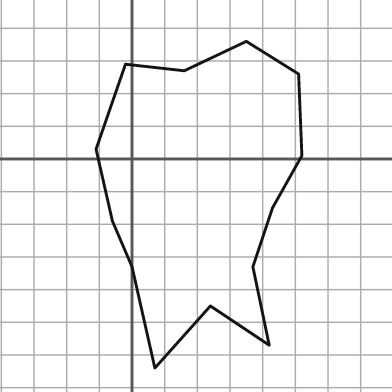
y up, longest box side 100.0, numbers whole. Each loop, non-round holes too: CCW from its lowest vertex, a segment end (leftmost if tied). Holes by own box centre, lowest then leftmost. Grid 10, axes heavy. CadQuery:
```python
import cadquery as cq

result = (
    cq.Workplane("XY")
    .moveTo(7.0, -64.0)
    .lineTo(24.0, -45.0)
    .lineTo(42.0, -57.0)
    .lineTo(37.0, -33.0)
    .lineTo(43.0, -15.0)
    .lineTo(52.0, 1.0)
    .lineTo(51.0, 26.0)
    .lineTo(35.0, 36.0)
    .lineTo(16.0, 27.0)
    .lineTo(-2.0, 29.0)
    .lineTo(-11.0, 3.0)
    .lineTo(-6.0, -19.0)
    .lineTo(0.0, -33.0)
    .close()
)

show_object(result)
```